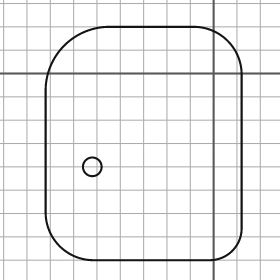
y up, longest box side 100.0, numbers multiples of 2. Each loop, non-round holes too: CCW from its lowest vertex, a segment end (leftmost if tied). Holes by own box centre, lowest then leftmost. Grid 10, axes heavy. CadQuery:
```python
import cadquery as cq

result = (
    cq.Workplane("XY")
    .moveTo(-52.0, -80.0)
    .lineTo(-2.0, -80.0)
    .threePointArc((8.0, -76.0), (12.0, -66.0))
    .lineTo(12.0, 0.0)
    .threePointArc((6.0, 14.0), (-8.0, 20.0))
    .lineTo(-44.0, 20.0)
    .threePointArc((-64.0, 12.0), (-72.0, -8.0))
    .lineTo(-72.0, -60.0)
    .threePointArc((-66.0, -74.0), (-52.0, -80.0))
    .close()
    .moveTo(-52.0, -40.0)
    .circle(4.0)
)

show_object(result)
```